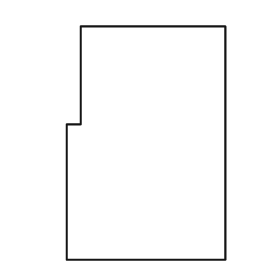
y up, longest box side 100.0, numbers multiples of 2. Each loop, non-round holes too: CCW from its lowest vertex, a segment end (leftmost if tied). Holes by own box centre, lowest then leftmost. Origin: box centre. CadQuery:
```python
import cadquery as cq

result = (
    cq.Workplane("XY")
    .moveTo(-34.0, -50.0)
    .lineTo(34.0, -50.0)
    .lineTo(34.0, 50.0)
    .lineTo(-28.0, 50.0)
    .lineTo(-28.0, 8.0)
    .lineTo(-34.0, 8.0)
    .close()
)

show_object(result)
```